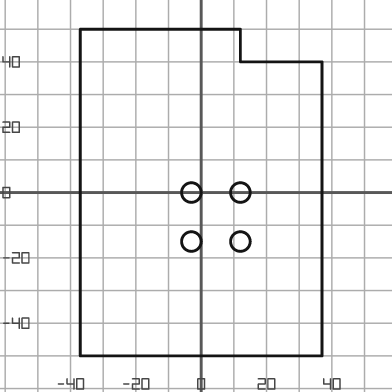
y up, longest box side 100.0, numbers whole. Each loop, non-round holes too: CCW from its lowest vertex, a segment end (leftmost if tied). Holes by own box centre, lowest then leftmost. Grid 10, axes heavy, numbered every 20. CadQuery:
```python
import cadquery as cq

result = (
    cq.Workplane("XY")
    .moveTo(-37.0, -50.0)
    .lineTo(37.0, -50.0)
    .lineTo(37.0, 40.0)
    .lineTo(12.0, 40.0)
    .lineTo(12.0, 50.0)
    .lineTo(-37.0, 50.0)
    .close()
    .moveTo(-3.0, -15.0)
    .circle(3.0)
    .moveTo(12.0, -15.0)
    .circle(3.0)
    .moveTo(-3.0, 0.0)
    .circle(3.0)
    .moveTo(12.0, 0.0)
    .circle(3.0)
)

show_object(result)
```